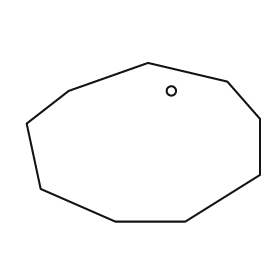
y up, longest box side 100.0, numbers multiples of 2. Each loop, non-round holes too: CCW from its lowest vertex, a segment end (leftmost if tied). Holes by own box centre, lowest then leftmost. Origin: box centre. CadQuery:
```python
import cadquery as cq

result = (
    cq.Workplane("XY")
    .moveTo(-12.0, -34.0)
    .lineTo(18.0, -34.0)
    .lineTo(50.0, -14.0)
    .lineTo(50.0, 10.0)
    .lineTo(36.0, 26.0)
    .lineTo(2.0, 34.0)
    .lineTo(-32.0, 22.0)
    .lineTo(-50.0, 8.0)
    .lineTo(-44.0, -20.0)
    .close()
    .moveTo(12.0, 22.0)
    .circle(2.0)
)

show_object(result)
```